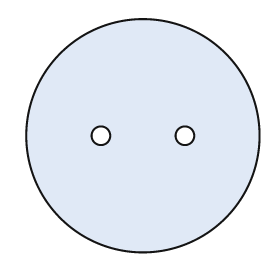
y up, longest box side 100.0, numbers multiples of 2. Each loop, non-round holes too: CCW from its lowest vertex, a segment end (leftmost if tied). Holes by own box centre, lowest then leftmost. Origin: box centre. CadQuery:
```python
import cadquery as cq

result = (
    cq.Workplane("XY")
    .moveTo(0.0, 0.0)
    .circle(50.0)
    .moveTo(-18.0, 0.0)
    .circle(4.0)
    .moveTo(18.0, 0.0)
    .circle(4.0)
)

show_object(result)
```